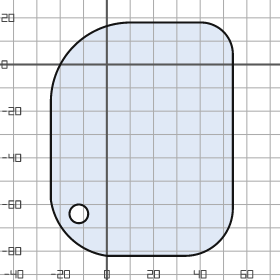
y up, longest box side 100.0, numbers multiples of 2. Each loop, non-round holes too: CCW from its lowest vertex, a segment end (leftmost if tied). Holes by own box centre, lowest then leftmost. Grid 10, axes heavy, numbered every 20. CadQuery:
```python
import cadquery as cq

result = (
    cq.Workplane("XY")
    .moveTo(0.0, -82.0)
    .lineTo(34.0, -82.0)
    .threePointArc((48.0, -76.0), (54.0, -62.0))
    .lineTo(54.0, 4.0)
    .threePointArc((50.0, 14.0), (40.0, 18.0))
    .lineTo(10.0, 18.0)
    .threePointArc((-14.0, 8.0), (-24.0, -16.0))
    .lineTo(-24.0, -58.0)
    .threePointArc((-16.0, -74.0), (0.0, -82.0))
    .close()
    .moveTo(-12.0, -64.0)
    .circle(4.0)
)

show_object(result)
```